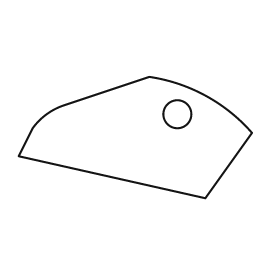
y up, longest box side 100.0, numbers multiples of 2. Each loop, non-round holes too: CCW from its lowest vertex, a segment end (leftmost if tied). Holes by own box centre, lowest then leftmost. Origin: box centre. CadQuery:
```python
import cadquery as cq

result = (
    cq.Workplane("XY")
    .moveTo(30.0, -26.0)
    .lineTo(50.0, 2.0)
    .threePointArc((30.0, 18.0), (6.0, 26.0))
    .lineTo(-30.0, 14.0)
    .threePointArc((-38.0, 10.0), (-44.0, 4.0))
    .lineTo(-50.0, -8.0)
    .close()
    .moveTo(18.0, 10.0)
    .circle(6.0)
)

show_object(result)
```